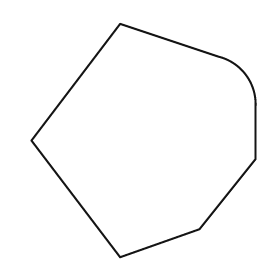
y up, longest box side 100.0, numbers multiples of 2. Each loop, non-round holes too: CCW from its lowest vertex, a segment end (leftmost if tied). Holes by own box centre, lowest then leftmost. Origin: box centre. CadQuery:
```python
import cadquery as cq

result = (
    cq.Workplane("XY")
    .moveTo(-10.0, -50.0)
    .lineTo(24.0, -38.0)
    .lineTo(48.0, -8.0)
    .lineTo(48.0, 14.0)
    .threePointArc((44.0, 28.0), (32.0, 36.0))
    .lineTo(-10.0, 50.0)
    .lineTo(-48.0, 0.0)
    .close()
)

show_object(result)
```